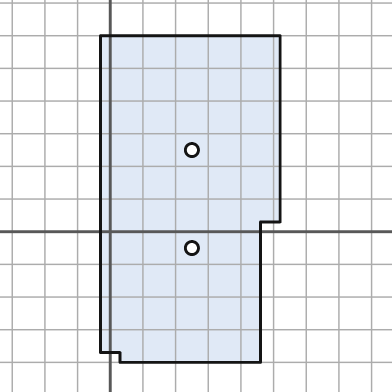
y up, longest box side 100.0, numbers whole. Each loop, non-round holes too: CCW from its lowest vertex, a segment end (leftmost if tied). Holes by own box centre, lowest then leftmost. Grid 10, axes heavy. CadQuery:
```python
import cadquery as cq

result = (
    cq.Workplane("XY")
    .moveTo(3.0, -40.0)
    .lineTo(46.0, -40.0)
    .lineTo(46.0, 3.0)
    .lineTo(52.0, 3.0)
    .lineTo(52.0, 60.0)
    .lineTo(-3.0, 60.0)
    .lineTo(-3.0, -37.0)
    .lineTo(3.0, -37.0)
    .close()
    .moveTo(25.0, -5.0)
    .circle(2.0)
    .moveTo(25.0, 25.0)
    .circle(2.0)
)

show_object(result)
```